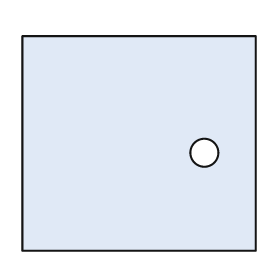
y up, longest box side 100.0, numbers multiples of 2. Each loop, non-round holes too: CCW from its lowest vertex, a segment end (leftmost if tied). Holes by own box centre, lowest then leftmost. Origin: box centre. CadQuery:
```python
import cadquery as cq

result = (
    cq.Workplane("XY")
    .moveTo(-50.0, -46.0)
    .lineTo(50.0, -46.0)
    .lineTo(50.0, 46.0)
    .lineTo(-50.0, 46.0)
    .close()
    .moveTo(28.0, -4.0)
    .circle(6.0)
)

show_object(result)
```